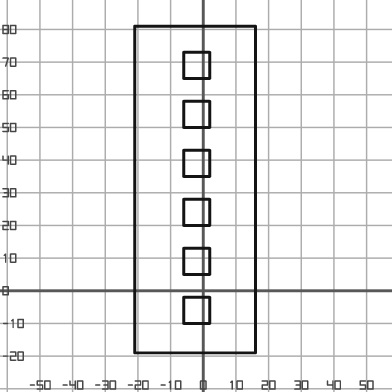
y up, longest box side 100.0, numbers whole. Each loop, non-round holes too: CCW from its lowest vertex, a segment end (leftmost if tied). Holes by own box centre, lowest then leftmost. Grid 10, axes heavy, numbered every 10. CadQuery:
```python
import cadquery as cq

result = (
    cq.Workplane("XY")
    .moveTo(-21.0, -19.0)
    .lineTo(16.0, -19.0)
    .lineTo(16.0, 81.0)
    .lineTo(-21.0, 81.0)
    .close()
    .moveTo(-6.0, -10.0)
    .lineTo(2.0, -10.0)
    .lineTo(2.0, -2.0)
    .lineTo(-6.0, -2.0)
    .close()
    .moveTo(-6.0, 5.0)
    .lineTo(2.0, 5.0)
    .lineTo(2.0, 13.0)
    .lineTo(-6.0, 13.0)
    .close()
    .moveTo(-6.0, 20.0)
    .lineTo(2.0, 20.0)
    .lineTo(2.0, 28.0)
    .lineTo(-6.0, 28.0)
    .close()
    .moveTo(-6.0, 35.0)
    .lineTo(2.0, 35.0)
    .lineTo(2.0, 43.0)
    .lineTo(-6.0, 43.0)
    .close()
    .moveTo(-6.0, 50.0)
    .lineTo(2.0, 50.0)
    .lineTo(2.0, 58.0)
    .lineTo(-6.0, 58.0)
    .close()
    .moveTo(-6.0, 65.0)
    .lineTo(2.0, 65.0)
    .lineTo(2.0, 73.0)
    .lineTo(-6.0, 73.0)
    .close()
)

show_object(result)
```